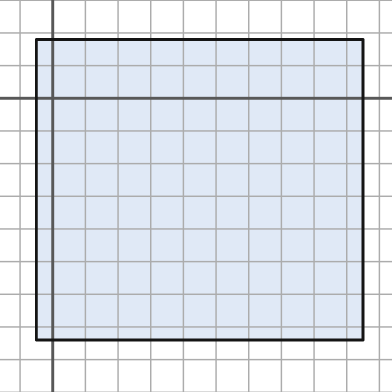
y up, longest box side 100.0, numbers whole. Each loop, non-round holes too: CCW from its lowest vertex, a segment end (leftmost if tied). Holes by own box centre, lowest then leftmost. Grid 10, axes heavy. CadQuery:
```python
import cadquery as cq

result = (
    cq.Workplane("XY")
    .moveTo(-5.0, -74.0)
    .lineTo(95.0, -74.0)
    .lineTo(95.0, 18.0)
    .lineTo(-5.0, 18.0)
    .close()
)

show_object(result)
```